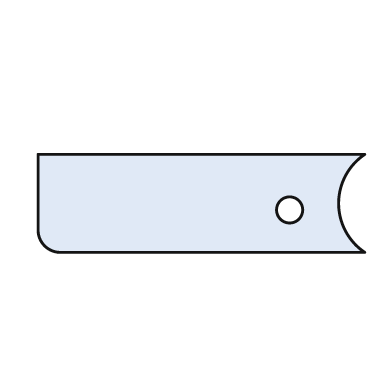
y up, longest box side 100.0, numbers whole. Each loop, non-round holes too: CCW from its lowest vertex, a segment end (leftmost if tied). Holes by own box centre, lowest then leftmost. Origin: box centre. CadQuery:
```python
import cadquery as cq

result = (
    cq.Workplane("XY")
    .moveTo(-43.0, -15.0)
    .lineTo(50.0, -15.0)
    .threePointArc((42.0, 0.0), (50.0, 15.0))
    .lineTo(-50.0, 15.0)
    .lineTo(-50.0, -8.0)
    .threePointArc((-48.0, -13.0), (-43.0, -15.0))
    .close()
    .moveTo(27.0, -2.0)
    .circle(4.0)
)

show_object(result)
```